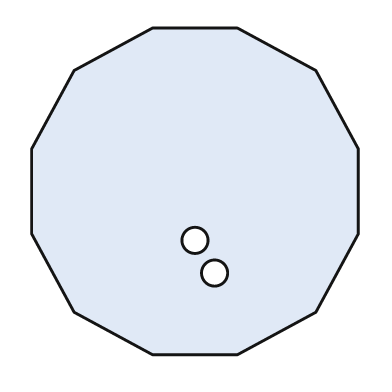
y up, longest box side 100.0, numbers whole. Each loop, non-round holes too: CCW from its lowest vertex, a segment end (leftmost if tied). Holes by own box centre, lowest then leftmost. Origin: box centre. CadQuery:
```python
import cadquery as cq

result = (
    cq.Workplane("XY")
    .moveTo(-13.0, -50.0)
    .lineTo(13.0, -50.0)
    .lineTo(37.0, -37.0)
    .lineTo(50.0, -13.0)
    .lineTo(50.0, 13.0)
    .lineTo(37.0, 37.0)
    .lineTo(13.0, 50.0)
    .lineTo(-13.0, 50.0)
    .lineTo(-37.0, 37.0)
    .lineTo(-50.0, 13.0)
    .lineTo(-50.0, -13.0)
    .lineTo(-37.0, -37.0)
    .close()
    .moveTo(6.0, -25.0)
    .circle(4.0)
    .moveTo(0.0, -15.0)
    .circle(4.0)
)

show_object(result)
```